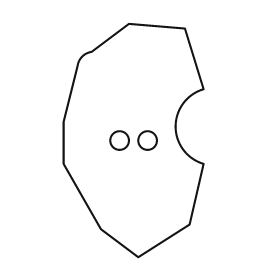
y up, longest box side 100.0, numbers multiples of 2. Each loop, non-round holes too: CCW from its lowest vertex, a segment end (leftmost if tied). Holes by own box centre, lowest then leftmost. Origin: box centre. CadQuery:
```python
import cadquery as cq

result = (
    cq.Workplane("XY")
    .moveTo(2.0, -50.0)
    .lineTo(24.0, -36.0)
    .lineTo(30.0, -10.0)
    .threePointArc((18.0, 6.0), (30.0, 22.0))
    .lineTo(22.0, 48.0)
    .lineTo(-2.0, 50.0)
    .lineTo(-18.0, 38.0)
    .threePointArc((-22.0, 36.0), (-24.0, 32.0))
    .lineTo(-30.0, 8.0)
    .lineTo(-30.0, -10.0)
    .lineTo(-14.0, -38.0)
    .close()
    .moveTo(-6.0, 0.0)
    .circle(4.0)
    .moveTo(6.0, 0.0)
    .circle(4.0)
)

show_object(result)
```